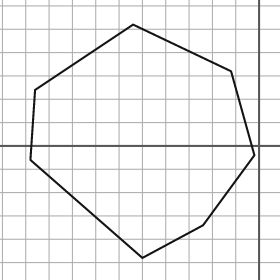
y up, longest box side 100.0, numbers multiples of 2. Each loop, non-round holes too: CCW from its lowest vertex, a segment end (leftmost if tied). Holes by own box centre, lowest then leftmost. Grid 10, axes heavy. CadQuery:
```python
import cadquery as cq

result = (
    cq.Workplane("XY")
    .moveTo(-50.0, -48.0)
    .lineTo(-24.0, -34.0)
    .lineTo(-2.0, -4.0)
    .lineTo(-12.0, 32.0)
    .lineTo(-54.0, 52.0)
    .lineTo(-96.0, 24.0)
    .lineTo(-98.0, -6.0)
    .close()
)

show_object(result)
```